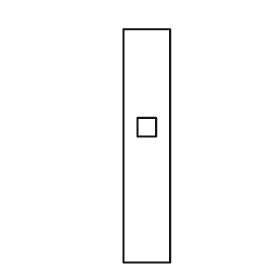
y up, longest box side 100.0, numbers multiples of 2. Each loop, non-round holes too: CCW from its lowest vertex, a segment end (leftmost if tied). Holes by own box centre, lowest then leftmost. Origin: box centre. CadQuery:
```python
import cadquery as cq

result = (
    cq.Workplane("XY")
    .moveTo(-10.0, -50.0)
    .lineTo(10.0, -50.0)
    .lineTo(10.0, 50.0)
    .lineTo(-10.0, 50.0)
    .close()
    .moveTo(-4.0, 4.0)
    .lineTo(4.0, 4.0)
    .lineTo(4.0, 12.0)
    .lineTo(-4.0, 12.0)
    .close()
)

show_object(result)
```